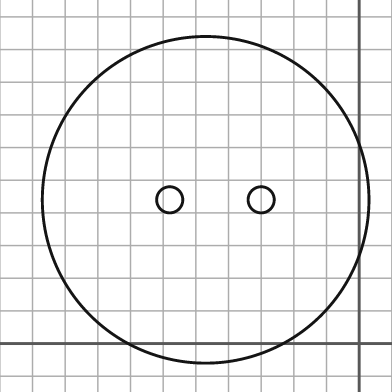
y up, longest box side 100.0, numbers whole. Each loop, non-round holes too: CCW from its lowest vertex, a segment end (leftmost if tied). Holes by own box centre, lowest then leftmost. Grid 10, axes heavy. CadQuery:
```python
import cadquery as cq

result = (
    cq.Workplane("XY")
    .moveTo(-47.0, 44.0)
    .circle(50.0)
    .moveTo(-58.0, 44.0)
    .circle(4.0)
    .moveTo(-30.0, 44.0)
    .circle(4.0)
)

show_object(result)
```